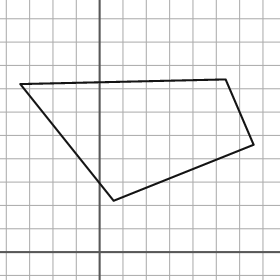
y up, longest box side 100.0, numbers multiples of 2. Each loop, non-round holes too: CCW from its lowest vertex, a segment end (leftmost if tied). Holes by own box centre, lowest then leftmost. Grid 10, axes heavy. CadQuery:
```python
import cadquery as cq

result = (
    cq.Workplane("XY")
    .moveTo(6.0, 22.0)
    .lineTo(66.0, 46.0)
    .lineTo(54.0, 74.0)
    .lineTo(-34.0, 72.0)
    .close()
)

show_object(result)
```